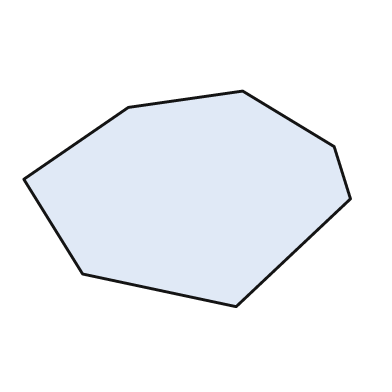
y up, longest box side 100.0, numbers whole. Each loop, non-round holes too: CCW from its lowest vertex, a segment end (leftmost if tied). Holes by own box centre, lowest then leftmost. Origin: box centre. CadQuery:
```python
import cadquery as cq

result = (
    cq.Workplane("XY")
    .moveTo(15.0, -33.0)
    .lineTo(50.0, 0.0)
    .lineTo(45.0, 16.0)
    .lineTo(17.0, 33.0)
    .lineTo(-18.0, 28.0)
    .lineTo(-50.0, 6.0)
    .lineTo(-32.0, -23.0)
    .close()
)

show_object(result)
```